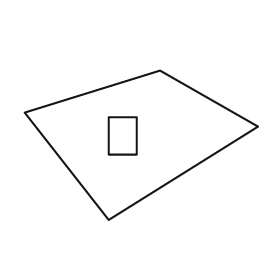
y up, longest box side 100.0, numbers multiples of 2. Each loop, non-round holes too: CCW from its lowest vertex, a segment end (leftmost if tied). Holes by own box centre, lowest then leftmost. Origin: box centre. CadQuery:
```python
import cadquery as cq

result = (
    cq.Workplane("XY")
    .moveTo(-14.0, -32.0)
    .lineTo(50.0, 8.0)
    .lineTo(8.0, 32.0)
    .lineTo(-50.0, 14.0)
    .close()
    .moveTo(-14.0, -4.0)
    .lineTo(-2.0, -4.0)
    .lineTo(-2.0, 12.0)
    .lineTo(-14.0, 12.0)
    .close()
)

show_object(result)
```